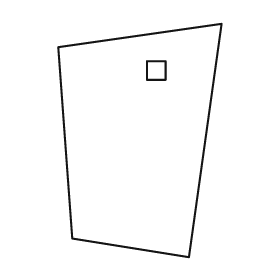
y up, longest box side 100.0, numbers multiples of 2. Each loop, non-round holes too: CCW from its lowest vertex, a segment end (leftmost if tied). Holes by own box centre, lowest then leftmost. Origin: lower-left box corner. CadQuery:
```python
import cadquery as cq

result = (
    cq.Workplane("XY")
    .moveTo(56.0, 0.0)
    .lineTo(70.0, 100.0)
    .lineTo(0.0, 90.0)
    .lineTo(6.0, 8.0)
    .close()
    .moveTo(38.0, 76.0)
    .lineTo(46.0, 76.0)
    .lineTo(46.0, 84.0)
    .lineTo(38.0, 84.0)
    .close()
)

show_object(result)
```